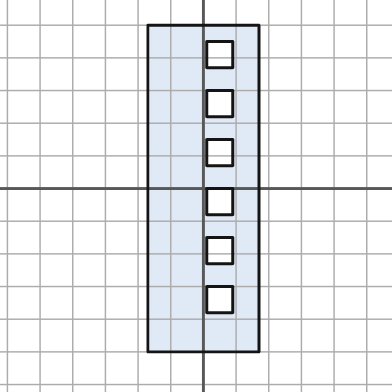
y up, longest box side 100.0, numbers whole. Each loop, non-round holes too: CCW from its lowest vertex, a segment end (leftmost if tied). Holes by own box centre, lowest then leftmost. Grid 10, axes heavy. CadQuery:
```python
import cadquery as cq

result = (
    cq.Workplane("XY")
    .moveTo(-17.0, -50.0)
    .lineTo(17.0, -50.0)
    .lineTo(17.0, 50.0)
    .lineTo(-17.0, 50.0)
    .close()
    .moveTo(1.0, -38.0)
    .lineTo(9.0, -38.0)
    .lineTo(9.0, -30.0)
    .lineTo(1.0, -30.0)
    .close()
    .moveTo(1.0, -23.0)
    .lineTo(9.0, -23.0)
    .lineTo(9.0, -15.0)
    .lineTo(1.0, -15.0)
    .close()
    .moveTo(1.0, -8.0)
    .lineTo(9.0, -8.0)
    .lineTo(9.0, 0.0)
    .lineTo(1.0, 0.0)
    .close()
    .moveTo(1.0, 7.0)
    .lineTo(9.0, 7.0)
    .lineTo(9.0, 15.0)
    .lineTo(1.0, 15.0)
    .close()
    .moveTo(1.0, 22.0)
    .lineTo(9.0, 22.0)
    .lineTo(9.0, 30.0)
    .lineTo(1.0, 30.0)
    .close()
    .moveTo(1.0, 37.0)
    .lineTo(9.0, 37.0)
    .lineTo(9.0, 45.0)
    .lineTo(1.0, 45.0)
    .close()
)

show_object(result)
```